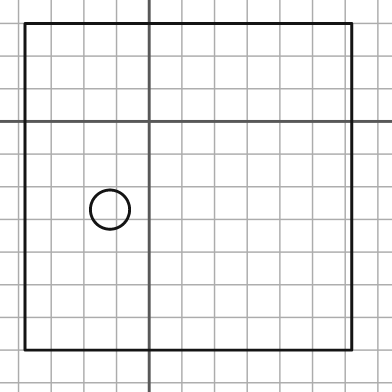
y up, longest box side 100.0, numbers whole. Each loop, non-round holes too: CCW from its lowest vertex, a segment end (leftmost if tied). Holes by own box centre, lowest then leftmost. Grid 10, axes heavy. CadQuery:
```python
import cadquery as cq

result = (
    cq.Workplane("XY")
    .moveTo(-38.0, -70.0)
    .lineTo(62.0, -70.0)
    .lineTo(62.0, 30.0)
    .lineTo(-38.0, 30.0)
    .close()
    .moveTo(-12.0, -27.0)
    .circle(6.0)
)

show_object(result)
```